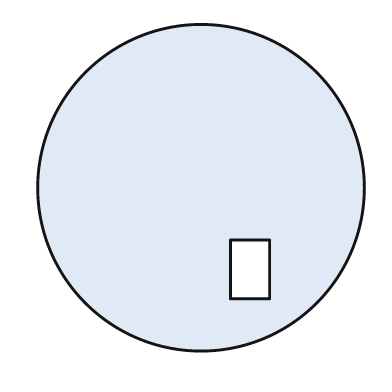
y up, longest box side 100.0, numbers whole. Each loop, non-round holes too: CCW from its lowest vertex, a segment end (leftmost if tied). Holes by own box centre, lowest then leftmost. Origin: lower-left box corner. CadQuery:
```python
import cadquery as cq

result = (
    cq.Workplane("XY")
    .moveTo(50.0, 50.0)
    .circle(50.0)
    .moveTo(59.0, 16.0)
    .lineTo(71.0, 16.0)
    .lineTo(71.0, 34.0)
    .lineTo(59.0, 34.0)
    .close()
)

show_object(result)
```